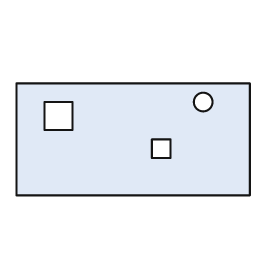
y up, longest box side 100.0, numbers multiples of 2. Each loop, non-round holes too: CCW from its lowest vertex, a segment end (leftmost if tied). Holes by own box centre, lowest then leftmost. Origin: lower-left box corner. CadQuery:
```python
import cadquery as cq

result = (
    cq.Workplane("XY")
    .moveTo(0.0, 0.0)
    .lineTo(100.0, 0.0)
    .lineTo(100.0, 48.0)
    .lineTo(0.0, 48.0)
    .close()
    .moveTo(58.0, 16.0)
    .lineTo(66.0, 16.0)
    .lineTo(66.0, 24.0)
    .lineTo(58.0, 24.0)
    .close()
    .moveTo(12.0, 28.0)
    .lineTo(24.0, 28.0)
    .lineTo(24.0, 40.0)
    .lineTo(12.0, 40.0)
    .close()
    .moveTo(80.0, 40.0)
    .circle(4.0)
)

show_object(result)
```